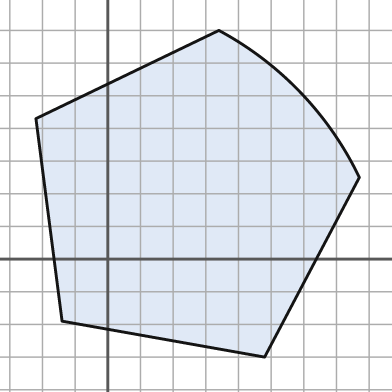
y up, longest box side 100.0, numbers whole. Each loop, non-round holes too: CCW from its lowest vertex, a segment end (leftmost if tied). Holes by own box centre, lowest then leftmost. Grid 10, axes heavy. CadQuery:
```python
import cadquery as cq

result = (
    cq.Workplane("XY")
    .moveTo(48.0, -30.0)
    .lineTo(77.0, 25.0)
    .threePointArc((59.0, 51.0), (34.0, 70.0))
    .lineTo(-22.0, 43.0)
    .lineTo(-14.0, -19.0)
    .close()
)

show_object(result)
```